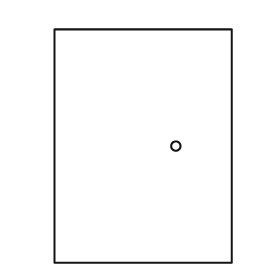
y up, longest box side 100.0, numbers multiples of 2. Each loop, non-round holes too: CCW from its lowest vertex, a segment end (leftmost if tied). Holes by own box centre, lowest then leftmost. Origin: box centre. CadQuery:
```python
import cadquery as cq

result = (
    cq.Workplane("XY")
    .moveTo(-38.0, -50.0)
    .lineTo(38.0, -50.0)
    .lineTo(38.0, 50.0)
    .lineTo(-38.0, 50.0)
    .close()
    .moveTo(14.0, 0.0)
    .circle(2.0)
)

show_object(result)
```